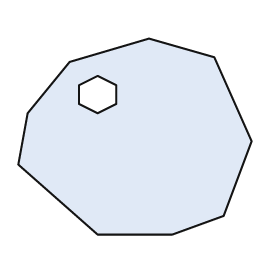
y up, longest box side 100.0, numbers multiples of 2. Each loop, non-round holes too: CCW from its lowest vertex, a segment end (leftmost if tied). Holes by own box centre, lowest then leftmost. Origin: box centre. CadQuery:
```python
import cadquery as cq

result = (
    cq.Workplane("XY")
    .moveTo(-16.0, -42.0)
    .lineTo(16.0, -42.0)
    .lineTo(38.0, -34.0)
    .lineTo(50.0, -2.0)
    .lineTo(34.0, 34.0)
    .lineTo(6.0, 42.0)
    .lineTo(-28.0, 32.0)
    .lineTo(-46.0, 10.0)
    .lineTo(-50.0, -12.0)
    .close()
    .moveTo(-16.0, 10.0)
    .lineTo(-8.0, 14.0)
    .lineTo(-8.0, 22.0)
    .lineTo(-16.0, 26.0)
    .lineTo(-24.0, 22.0)
    .lineTo(-24.0, 14.0)
    .close()
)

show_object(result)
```